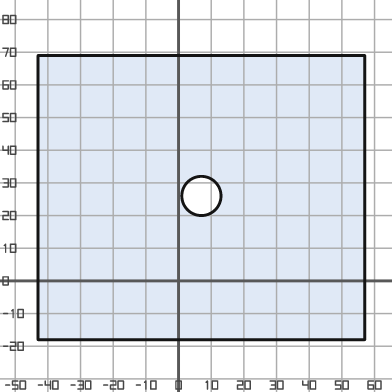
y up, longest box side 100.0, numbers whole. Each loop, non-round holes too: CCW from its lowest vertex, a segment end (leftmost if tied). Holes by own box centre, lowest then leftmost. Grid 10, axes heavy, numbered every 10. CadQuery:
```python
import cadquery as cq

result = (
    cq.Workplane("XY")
    .moveTo(-43.0, -18.0)
    .lineTo(57.0, -18.0)
    .lineTo(57.0, 69.0)
    .lineTo(-43.0, 69.0)
    .close()
    .moveTo(7.0, 26.0)
    .circle(6.0)
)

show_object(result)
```